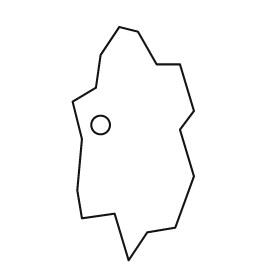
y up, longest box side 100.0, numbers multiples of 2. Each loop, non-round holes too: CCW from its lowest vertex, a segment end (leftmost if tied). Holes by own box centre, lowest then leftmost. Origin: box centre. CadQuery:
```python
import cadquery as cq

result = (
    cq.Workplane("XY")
    .moveTo(-2.0, -50.0)
    .lineTo(6.0, -38.0)
    .lineTo(18.0, -36.0)
    .lineTo(26.0, -14.0)
    .lineTo(20.0, 6.0)
    .lineTo(26.0, 14.0)
    .lineTo(20.0, 34.0)
    .lineTo(10.0, 34.0)
    .lineTo(2.0, 48.0)
    .lineTo(-6.0, 50.0)
    .lineTo(-14.0, 38.0)
    .lineTo(-16.0, 24.0)
    .lineTo(-26.0, 18.0)
    .lineTo(-22.0, 2.0)
    .lineTo(-24.0, -20.0)
    .lineTo(-22.0, -32.0)
    .lineTo(-8.0, -30.0)
    .close()
    .moveTo(-14.0, 8.0)
    .circle(4.0)
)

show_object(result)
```